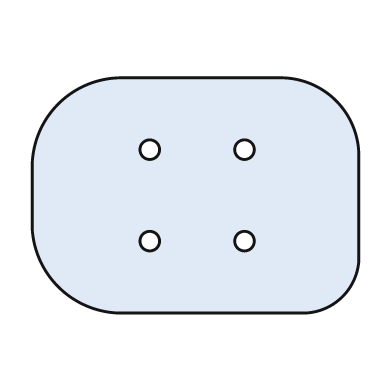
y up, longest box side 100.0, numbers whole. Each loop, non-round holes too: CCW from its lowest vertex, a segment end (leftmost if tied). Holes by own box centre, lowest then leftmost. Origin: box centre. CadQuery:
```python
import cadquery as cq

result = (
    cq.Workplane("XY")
    .moveTo(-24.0, -36.0)
    .lineTo(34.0, -36.0)
    .threePointArc((45.0, -31.0), (50.0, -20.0))
    .lineTo(50.0, 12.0)
    .threePointArc((43.0, 29.0), (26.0, 36.0))
    .lineTo(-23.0, 36.0)
    .threePointArc((-42.0, 28.0), (-50.0, 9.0))
    .lineTo(-50.0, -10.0)
    .threePointArc((-42.0, -28.0), (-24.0, -36.0))
    .close()
    .moveTo(-14.0, -14.0)
    .circle(3.0)
    .moveTo(15.0, -14.0)
    .circle(3.0)
    .moveTo(-14.0, 14.0)
    .circle(3.0)
    .moveTo(15.0, 14.0)
    .circle(3.0)
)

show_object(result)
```